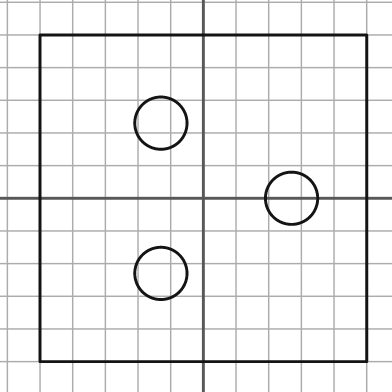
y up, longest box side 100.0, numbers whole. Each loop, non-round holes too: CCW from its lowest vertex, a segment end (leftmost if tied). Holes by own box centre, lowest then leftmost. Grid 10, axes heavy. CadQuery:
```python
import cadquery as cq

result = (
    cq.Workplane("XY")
    .moveTo(-50.0, -50.0)
    .lineTo(50.0, -50.0)
    .lineTo(50.0, 50.0)
    .lineTo(-50.0, 50.0)
    .close()
    .moveTo(-13.0, -23.0)
    .circle(8.0)
    .moveTo(27.0, 0.0)
    .circle(8.0)
    .moveTo(-13.0, 23.0)
    .circle(8.0)
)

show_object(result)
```